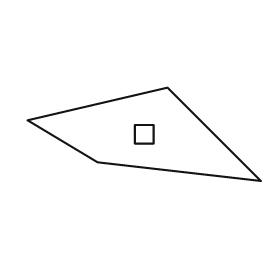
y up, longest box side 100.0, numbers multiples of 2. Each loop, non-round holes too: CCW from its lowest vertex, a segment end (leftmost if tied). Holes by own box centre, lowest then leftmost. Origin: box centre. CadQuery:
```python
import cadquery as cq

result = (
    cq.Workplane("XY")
    .moveTo(50.0, -20.0)
    .lineTo(10.0, 20.0)
    .lineTo(-50.0, 6.0)
    .lineTo(-20.0, -12.0)
    .close()
    .moveTo(-4.0, -4.0)
    .lineTo(4.0, -4.0)
    .lineTo(4.0, 4.0)
    .lineTo(-4.0, 4.0)
    .close()
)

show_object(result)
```